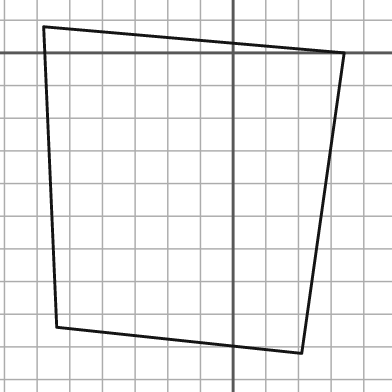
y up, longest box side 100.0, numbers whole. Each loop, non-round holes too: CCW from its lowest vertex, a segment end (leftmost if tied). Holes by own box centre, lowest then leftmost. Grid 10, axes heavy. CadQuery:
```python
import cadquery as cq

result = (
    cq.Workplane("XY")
    .moveTo(21.0, -92.0)
    .lineTo(34.0, 0.0)
    .lineTo(-58.0, 8.0)
    .lineTo(-54.0, -84.0)
    .close()
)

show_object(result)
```